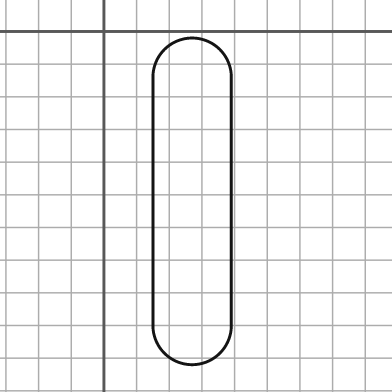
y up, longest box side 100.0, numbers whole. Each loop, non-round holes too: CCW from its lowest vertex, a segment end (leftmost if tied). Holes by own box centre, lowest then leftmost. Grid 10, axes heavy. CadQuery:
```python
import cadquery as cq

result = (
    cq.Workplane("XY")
    .moveTo(15.0, -90.0)
    .threePointArc((27.0, -102.0), (39.0, -90.0))
    .lineTo(39.0, -14.0)
    .threePointArc((27.0, -2.0), (15.0, -14.0))
    .close()
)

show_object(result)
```